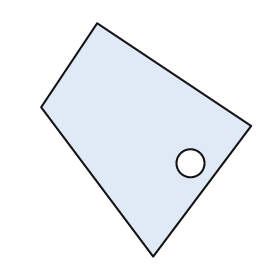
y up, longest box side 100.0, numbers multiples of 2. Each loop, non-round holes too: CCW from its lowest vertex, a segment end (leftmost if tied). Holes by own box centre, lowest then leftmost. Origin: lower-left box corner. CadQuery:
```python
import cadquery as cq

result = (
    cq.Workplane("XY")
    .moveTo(48.0, 0.0)
    .lineTo(90.0, 56.0)
    .lineTo(24.0, 100.0)
    .lineTo(0.0, 64.0)
    .close()
    .moveTo(64.0, 40.0)
    .circle(6.0)
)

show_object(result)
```